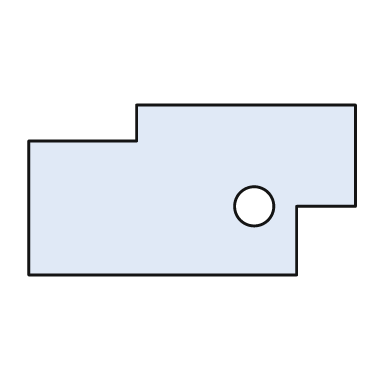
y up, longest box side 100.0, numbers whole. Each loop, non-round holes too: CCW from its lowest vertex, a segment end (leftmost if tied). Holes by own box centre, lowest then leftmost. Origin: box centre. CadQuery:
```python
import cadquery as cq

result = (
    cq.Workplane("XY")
    .moveTo(-50.0, -26.0)
    .lineTo(32.0, -26.0)
    .lineTo(32.0, -5.0)
    .lineTo(50.0, -5.0)
    .lineTo(50.0, 26.0)
    .lineTo(-17.0, 26.0)
    .lineTo(-17.0, 15.0)
    .lineTo(-50.0, 15.0)
    .close()
    .moveTo(19.0, -5.0)
    .circle(6.0)
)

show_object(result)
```